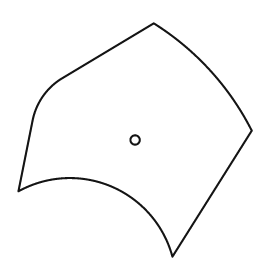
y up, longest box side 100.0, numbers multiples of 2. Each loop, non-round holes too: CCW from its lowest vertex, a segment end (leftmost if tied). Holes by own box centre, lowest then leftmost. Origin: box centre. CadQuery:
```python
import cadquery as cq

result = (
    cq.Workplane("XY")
    .moveTo(16.0, -50.0)
    .lineTo(50.0, 4.0)
    .threePointArc((32.0, 30.0), (8.0, 50.0))
    .lineTo(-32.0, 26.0)
    .threePointArc((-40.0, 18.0), (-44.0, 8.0))
    .lineTo(-50.0, -22.0)
    .threePointArc((-10.0, -20.0), (16.0, -50.0))
    .close()
    .moveTo(0.0, 0.0)
    .circle(2.0)
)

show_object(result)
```